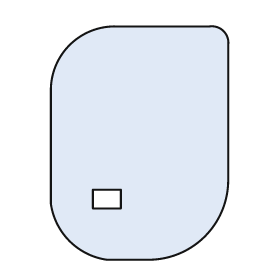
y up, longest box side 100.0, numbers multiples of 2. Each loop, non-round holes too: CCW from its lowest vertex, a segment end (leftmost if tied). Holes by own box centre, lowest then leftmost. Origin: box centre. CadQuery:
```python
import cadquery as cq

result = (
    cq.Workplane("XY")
    .moveTo(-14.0, -50.0)
    .lineTo(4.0, -50.0)
    .threePointArc((28.0, -40.0), (38.0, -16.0))
    .lineTo(38.0, 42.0)
    .threePointArc((36.0, 48.0), (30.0, 50.0))
    .lineTo(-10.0, 50.0)
    .threePointArc((-30.0, 42.0), (-38.0, 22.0))
    .lineTo(-38.0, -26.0)
    .threePointArc((-30.0, -42.0), (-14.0, -50.0))
    .close()
    .moveTo(-20.0, -28.0)
    .lineTo(-8.0, -28.0)
    .lineTo(-8.0, -20.0)
    .lineTo(-20.0, -20.0)
    .close()
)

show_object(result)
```